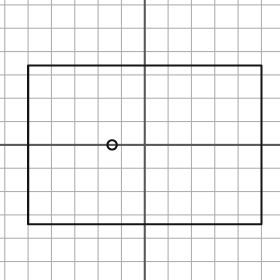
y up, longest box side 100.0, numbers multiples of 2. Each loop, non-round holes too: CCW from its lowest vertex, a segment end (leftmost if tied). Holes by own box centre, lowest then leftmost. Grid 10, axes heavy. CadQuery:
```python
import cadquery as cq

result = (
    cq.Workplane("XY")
    .moveTo(-50.0, -34.0)
    .lineTo(50.0, -34.0)
    .lineTo(50.0, 34.0)
    .lineTo(-50.0, 34.0)
    .close()
    .moveTo(-14.0, 0.0)
    .circle(2.0)
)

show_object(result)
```